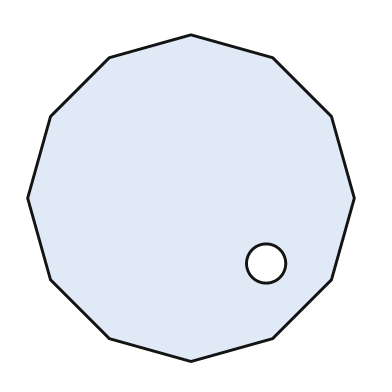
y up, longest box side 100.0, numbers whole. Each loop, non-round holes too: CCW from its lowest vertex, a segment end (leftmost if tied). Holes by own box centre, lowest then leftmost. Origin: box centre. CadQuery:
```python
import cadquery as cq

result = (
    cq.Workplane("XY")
    .moveTo(0.0, -50.0)
    .lineTo(25.0, -43.0)
    .lineTo(43.0, -25.0)
    .lineTo(50.0, 0.0)
    .lineTo(43.0, 25.0)
    .lineTo(25.0, 43.0)
    .lineTo(0.0, 50.0)
    .lineTo(-25.0, 43.0)
    .lineTo(-43.0, 25.0)
    .lineTo(-50.0, 0.0)
    .lineTo(-43.0, -25.0)
    .lineTo(-25.0, -43.0)
    .close()
    .moveTo(23.0, -20.0)
    .circle(6.0)
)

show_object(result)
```